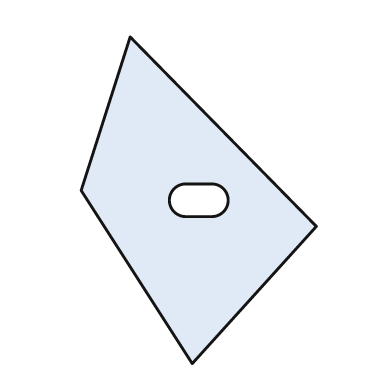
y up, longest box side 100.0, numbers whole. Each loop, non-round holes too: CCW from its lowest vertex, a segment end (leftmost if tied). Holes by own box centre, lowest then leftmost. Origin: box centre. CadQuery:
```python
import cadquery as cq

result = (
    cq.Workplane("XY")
    .moveTo(-2.0, -50.0)
    .lineTo(36.0, -8.0)
    .lineTo(-21.0, 50.0)
    .lineTo(-36.0, 3.0)
    .close()
    .moveTo(-4.0, -5.0)
    .lineTo(4.0, -5.0)
    .threePointArc((9.0, 0.0), (4.0, 5.0))
    .lineTo(-4.0, 5.0)
    .threePointArc((-9.0, 0.0), (-4.0, -5.0))
    .close()
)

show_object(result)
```